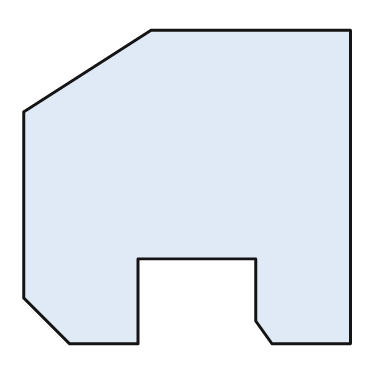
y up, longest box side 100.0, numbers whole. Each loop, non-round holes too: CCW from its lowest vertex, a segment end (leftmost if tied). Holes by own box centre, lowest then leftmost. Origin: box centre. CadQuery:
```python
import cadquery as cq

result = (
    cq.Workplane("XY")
    .moveTo(-36.0, -48.0)
    .lineTo(-15.0, -48.0)
    .lineTo(-15.0, -22.0)
    .lineTo(21.0, -22.0)
    .lineTo(21.0, -41.0)
    .lineTo(26.0, -48.0)
    .lineTo(50.0, -48.0)
    .lineTo(50.0, 48.0)
    .lineTo(-11.0, 48.0)
    .lineTo(-50.0, 23.0)
    .lineTo(-50.0, -34.0)
    .close()
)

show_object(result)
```